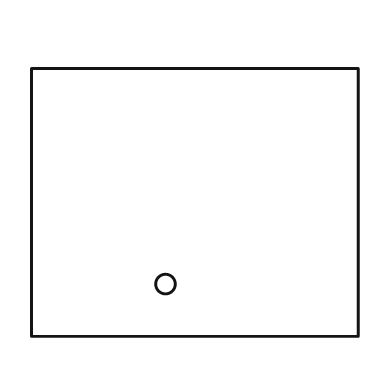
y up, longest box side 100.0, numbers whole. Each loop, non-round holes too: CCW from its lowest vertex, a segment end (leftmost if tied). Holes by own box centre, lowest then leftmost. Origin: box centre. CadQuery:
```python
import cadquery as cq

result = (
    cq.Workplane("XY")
    .moveTo(-50.0, -41.0)
    .lineTo(50.0, -41.0)
    .lineTo(50.0, 41.0)
    .lineTo(-50.0, 41.0)
    .close()
    .moveTo(-9.0, -25.0)
    .circle(3.0)
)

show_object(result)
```